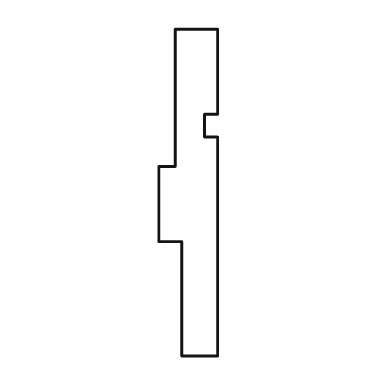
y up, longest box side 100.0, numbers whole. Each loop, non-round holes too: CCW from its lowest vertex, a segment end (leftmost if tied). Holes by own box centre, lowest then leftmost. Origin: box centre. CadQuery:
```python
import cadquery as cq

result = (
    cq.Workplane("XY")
    .moveTo(-2.0, -50.0)
    .lineTo(9.0, -50.0)
    .lineTo(9.0, 17.0)
    .lineTo(5.0, 17.0)
    .lineTo(5.0, 24.0)
    .lineTo(9.0, 24.0)
    .lineTo(9.0, 50.0)
    .lineTo(-4.0, 50.0)
    .lineTo(-4.0, 8.0)
    .lineTo(-9.0, 8.0)
    .lineTo(-9.0, -15.0)
    .lineTo(-2.0, -15.0)
    .close()
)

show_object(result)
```